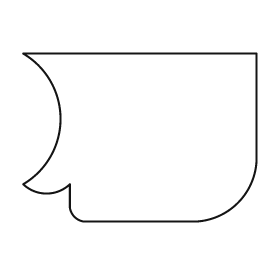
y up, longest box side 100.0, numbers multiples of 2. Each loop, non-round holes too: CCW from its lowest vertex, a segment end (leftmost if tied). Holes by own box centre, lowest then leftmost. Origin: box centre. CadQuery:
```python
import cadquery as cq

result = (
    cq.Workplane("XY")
    .moveTo(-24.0, -36.0)
    .lineTo(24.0, -36.0)
    .threePointArc((42.0, -28.0), (50.0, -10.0))
    .lineTo(50.0, 36.0)
    .lineTo(-50.0, 36.0)
    .threePointArc((-34.0, 8.0), (-50.0, -20.0))
    .threePointArc((-40.0, -24.0), (-30.0, -20.0))
    .lineTo(-30.0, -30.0)
    .threePointArc((-28.0, -34.0), (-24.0, -36.0))
    .close()
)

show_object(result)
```